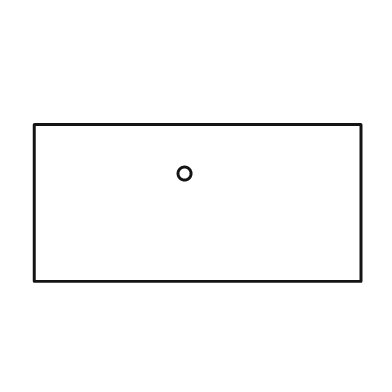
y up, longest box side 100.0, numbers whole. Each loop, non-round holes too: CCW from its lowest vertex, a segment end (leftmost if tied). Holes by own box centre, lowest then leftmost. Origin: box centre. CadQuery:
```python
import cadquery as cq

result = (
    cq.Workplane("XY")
    .moveTo(-50.0, -24.0)
    .lineTo(50.0, -24.0)
    .lineTo(50.0, 24.0)
    .lineTo(-50.0, 24.0)
    .close()
    .moveTo(-4.0, 9.0)
    .circle(2.0)
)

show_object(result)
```